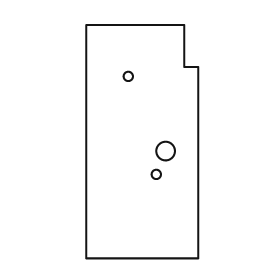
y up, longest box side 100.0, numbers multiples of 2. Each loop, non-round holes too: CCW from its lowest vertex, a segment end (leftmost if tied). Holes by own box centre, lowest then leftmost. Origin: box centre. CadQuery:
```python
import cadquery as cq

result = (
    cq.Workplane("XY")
    .moveTo(-24.0, -50.0)
    .lineTo(24.0, -50.0)
    .lineTo(24.0, 32.0)
    .lineTo(18.0, 32.0)
    .lineTo(18.0, 50.0)
    .lineTo(-24.0, 50.0)
    .close()
    .moveTo(6.0, -14.0)
    .circle(2.0)
    .moveTo(10.0, -4.0)
    .circle(4.0)
    .moveTo(-6.0, 28.0)
    .circle(2.0)
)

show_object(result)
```